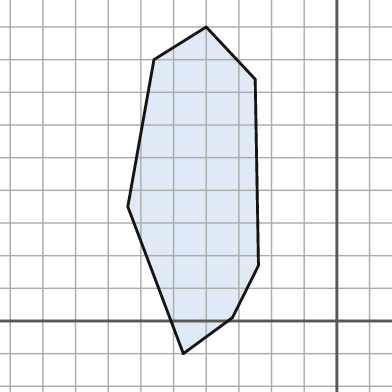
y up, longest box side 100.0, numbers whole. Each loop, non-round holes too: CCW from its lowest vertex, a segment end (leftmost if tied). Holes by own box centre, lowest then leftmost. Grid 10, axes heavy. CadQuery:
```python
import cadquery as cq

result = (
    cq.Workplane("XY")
    .moveTo(-47.0, -10.0)
    .lineTo(-32.0, 1.0)
    .lineTo(-24.0, 17.0)
    .lineTo(-25.0, 74.0)
    .lineTo(-40.0, 90.0)
    .lineTo(-56.0, 80.0)
    .lineTo(-64.0, 35.0)
    .close()
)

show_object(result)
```